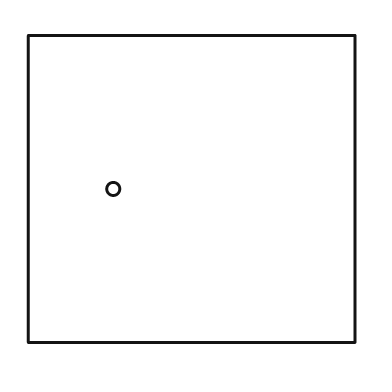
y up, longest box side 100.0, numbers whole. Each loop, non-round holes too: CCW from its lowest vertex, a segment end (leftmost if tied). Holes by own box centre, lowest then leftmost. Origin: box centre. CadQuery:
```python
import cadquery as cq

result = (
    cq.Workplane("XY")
    .moveTo(-50.0, -47.0)
    .lineTo(50.0, -47.0)
    .lineTo(50.0, 47.0)
    .lineTo(-50.0, 47.0)
    .close()
    .moveTo(-24.0, 0.0)
    .circle(2.0)
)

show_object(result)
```